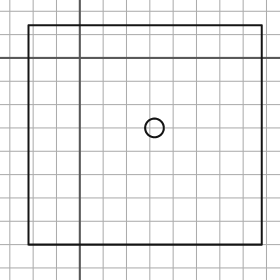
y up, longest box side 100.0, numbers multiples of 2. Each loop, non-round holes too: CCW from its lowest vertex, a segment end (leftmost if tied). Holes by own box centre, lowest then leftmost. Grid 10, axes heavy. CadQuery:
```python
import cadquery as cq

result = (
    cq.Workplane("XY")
    .moveTo(-22.0, -80.0)
    .lineTo(78.0, -80.0)
    .lineTo(78.0, 14.0)
    .lineTo(-22.0, 14.0)
    .close()
    .moveTo(32.0, -30.0)
    .circle(4.0)
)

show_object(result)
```